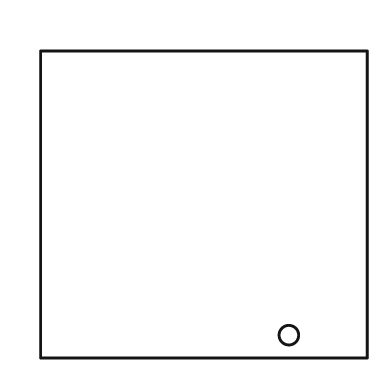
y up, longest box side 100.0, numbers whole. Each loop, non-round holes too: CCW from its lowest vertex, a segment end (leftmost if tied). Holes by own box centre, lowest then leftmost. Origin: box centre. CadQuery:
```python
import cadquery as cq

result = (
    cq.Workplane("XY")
    .moveTo(-50.0, -47.0)
    .lineTo(50.0, -47.0)
    .lineTo(50.0, 47.0)
    .lineTo(-50.0, 47.0)
    .close()
    .moveTo(26.0, -40.0)
    .circle(3.0)
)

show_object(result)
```